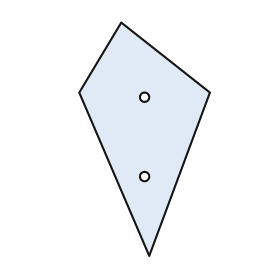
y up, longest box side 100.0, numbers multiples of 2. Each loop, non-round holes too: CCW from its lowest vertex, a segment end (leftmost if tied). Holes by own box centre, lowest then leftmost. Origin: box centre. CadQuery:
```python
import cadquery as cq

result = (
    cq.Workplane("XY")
    .moveTo(2.0, -50.0)
    .lineTo(28.0, 20.0)
    .lineTo(-10.0, 50.0)
    .lineTo(-28.0, 20.0)
    .close()
    .moveTo(0.0, -16.0)
    .circle(2.0)
    .moveTo(0.0, 18.0)
    .circle(2.0)
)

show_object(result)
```